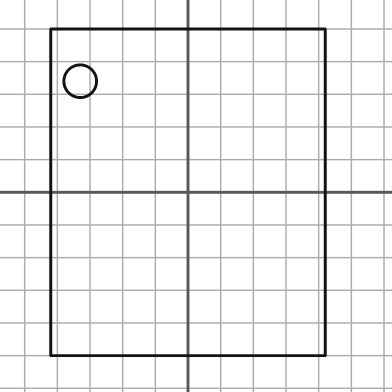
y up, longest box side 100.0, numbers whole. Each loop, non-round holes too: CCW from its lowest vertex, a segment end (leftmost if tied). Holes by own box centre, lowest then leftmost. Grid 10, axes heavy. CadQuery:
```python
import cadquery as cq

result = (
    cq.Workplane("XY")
    .moveTo(-42.0, -50.0)
    .lineTo(42.0, -50.0)
    .lineTo(42.0, 50.0)
    .lineTo(-42.0, 50.0)
    .close()
    .moveTo(-33.0, 34.0)
    .circle(5.0)
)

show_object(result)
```